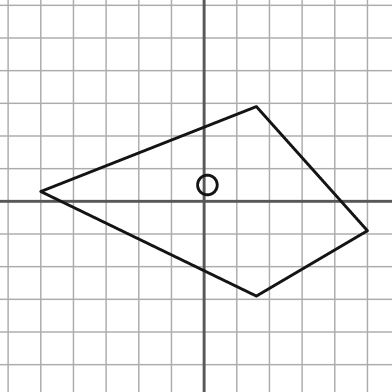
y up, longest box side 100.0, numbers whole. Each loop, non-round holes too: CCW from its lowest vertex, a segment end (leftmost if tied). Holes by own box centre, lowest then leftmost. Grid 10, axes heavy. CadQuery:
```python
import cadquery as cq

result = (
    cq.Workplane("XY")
    .moveTo(16.0, -29.0)
    .lineTo(50.0, -9.0)
    .lineTo(16.0, 29.0)
    .lineTo(-50.0, 3.0)
    .close()
    .moveTo(1.0, 5.0)
    .circle(3.0)
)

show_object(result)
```